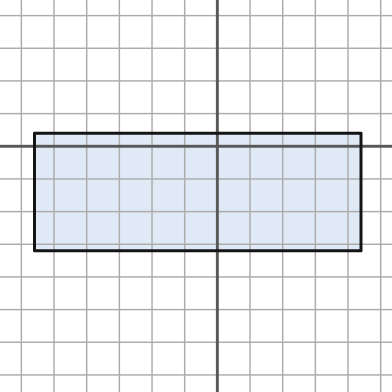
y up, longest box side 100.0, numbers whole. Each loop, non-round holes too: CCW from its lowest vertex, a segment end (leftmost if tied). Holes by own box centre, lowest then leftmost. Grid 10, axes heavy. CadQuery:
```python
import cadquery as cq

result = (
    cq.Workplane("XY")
    .moveTo(-56.0, -32.0)
    .lineTo(44.0, -32.0)
    .lineTo(44.0, 4.0)
    .lineTo(-56.0, 4.0)
    .close()
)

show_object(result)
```